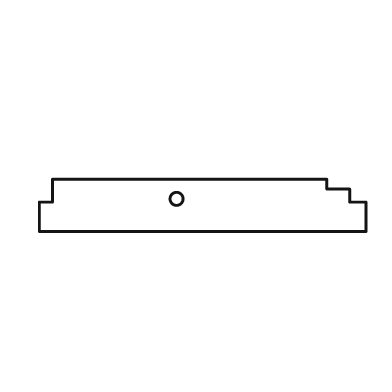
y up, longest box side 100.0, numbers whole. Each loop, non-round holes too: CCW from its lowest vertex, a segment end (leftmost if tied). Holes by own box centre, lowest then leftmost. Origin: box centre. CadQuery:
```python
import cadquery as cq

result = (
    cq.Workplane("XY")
    .moveTo(-50.0, -8.0)
    .lineTo(50.0, -8.0)
    .lineTo(50.0, 1.0)
    .lineTo(45.0, 1.0)
    .lineTo(45.0, 5.0)
    .lineTo(38.0, 5.0)
    .lineTo(38.0, 8.0)
    .lineTo(-46.0, 8.0)
    .lineTo(-46.0, 1.0)
    .lineTo(-50.0, 1.0)
    .close()
    .moveTo(-8.0, 2.0)
    .circle(2.0)
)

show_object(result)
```